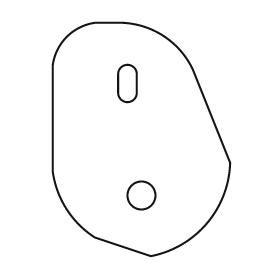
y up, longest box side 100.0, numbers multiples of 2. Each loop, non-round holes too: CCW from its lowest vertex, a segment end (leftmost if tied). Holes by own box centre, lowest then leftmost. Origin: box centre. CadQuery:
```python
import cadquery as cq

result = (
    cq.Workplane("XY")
    .moveTo(4.0, -50.0)
    .threePointArc((28.0, -36.0), (38.0, -10.0))
    .lineTo(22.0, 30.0)
    .threePointArc((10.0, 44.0), (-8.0, 50.0))
    .lineTo(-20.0, 50.0)
    .threePointArc((-32.0, 44.0), (-38.0, 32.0))
    .lineTo(-38.0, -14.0)
    .threePointArc((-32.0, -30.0), (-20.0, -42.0))
    .close()
    .moveTo(0.0, -24.0)
    .circle(6.0)
    .moveTo(-10.0, 20.0)
    .threePointArc((-6.0, 16.0), (-2.0, 20.0))
    .lineTo(-2.0, 28.0)
    .threePointArc((-6.0, 32.0), (-10.0, 28.0))
    .close()
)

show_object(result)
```